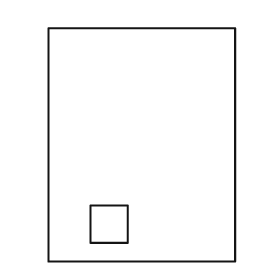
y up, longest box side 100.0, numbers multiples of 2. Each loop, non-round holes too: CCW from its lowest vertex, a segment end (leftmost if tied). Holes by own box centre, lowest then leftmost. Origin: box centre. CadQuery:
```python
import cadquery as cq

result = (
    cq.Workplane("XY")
    .moveTo(-40.0, -50.0)
    .lineTo(40.0, -50.0)
    .lineTo(40.0, 50.0)
    .lineTo(-40.0, 50.0)
    .close()
    .moveTo(-22.0, -42.0)
    .lineTo(-6.0, -42.0)
    .lineTo(-6.0, -26.0)
    .lineTo(-22.0, -26.0)
    .close()
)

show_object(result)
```